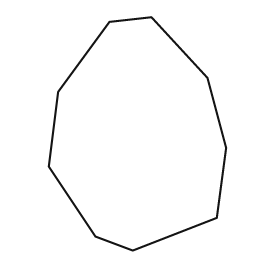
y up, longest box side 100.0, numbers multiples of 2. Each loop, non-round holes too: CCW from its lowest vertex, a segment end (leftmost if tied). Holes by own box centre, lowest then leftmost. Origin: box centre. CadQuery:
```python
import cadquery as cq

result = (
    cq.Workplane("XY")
    .moveTo(-2.0, -50.0)
    .lineTo(34.0, -36.0)
    .lineTo(38.0, -6.0)
    .lineTo(30.0, 24.0)
    .lineTo(6.0, 50.0)
    .lineTo(-12.0, 48.0)
    .lineTo(-34.0, 18.0)
    .lineTo(-38.0, -14.0)
    .lineTo(-18.0, -44.0)
    .close()
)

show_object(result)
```